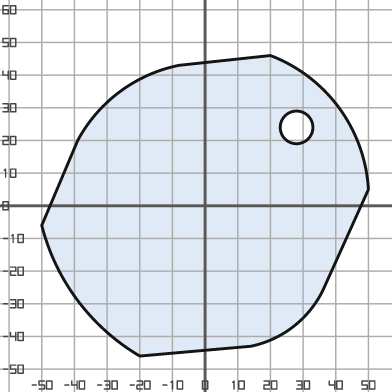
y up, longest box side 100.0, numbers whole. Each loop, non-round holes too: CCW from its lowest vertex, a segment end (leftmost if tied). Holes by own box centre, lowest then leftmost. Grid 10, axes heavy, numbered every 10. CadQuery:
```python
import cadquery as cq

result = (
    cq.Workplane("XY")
    .moveTo(-20.0, -46.0)
    .lineTo(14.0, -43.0)
    .threePointArc((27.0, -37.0), (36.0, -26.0))
    .lineTo(50.0, 5.0)
    .threePointArc((41.0, 30.0), (20.0, 46.0))
    .lineTo(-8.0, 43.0)
    .threePointArc((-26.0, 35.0), (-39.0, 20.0))
    .lineTo(-50.0, -6.0)
    .threePointArc((-39.0, -29.0), (-20.0, -46.0))
    .close()
    .moveTo(28.0, 24.0)
    .circle(5.0)
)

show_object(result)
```